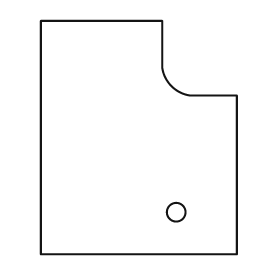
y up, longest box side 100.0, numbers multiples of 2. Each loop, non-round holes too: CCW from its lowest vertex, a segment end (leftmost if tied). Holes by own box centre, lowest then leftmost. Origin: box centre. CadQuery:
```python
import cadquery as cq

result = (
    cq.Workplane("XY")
    .moveTo(-42.0, -50.0)
    .lineTo(42.0, -50.0)
    .lineTo(42.0, 18.0)
    .lineTo(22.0, 18.0)
    .threePointArc((14.0, 22.0), (10.0, 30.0))
    .lineTo(10.0, 50.0)
    .lineTo(-42.0, 50.0)
    .close()
    .moveTo(16.0, -32.0)
    .circle(4.0)
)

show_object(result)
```